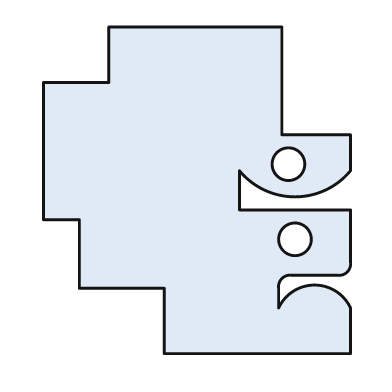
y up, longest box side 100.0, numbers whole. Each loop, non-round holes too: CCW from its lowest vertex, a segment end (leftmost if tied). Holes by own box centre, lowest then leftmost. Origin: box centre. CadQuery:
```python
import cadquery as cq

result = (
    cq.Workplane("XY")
    .moveTo(-10.0, -50.0)
    .lineTo(47.0, -50.0)
    .lineTo(47.0, -36.0)
    .threePointArc((36.0, -29.0), (25.0, -36.0))
    .lineTo(25.0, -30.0)
    .threePointArc((26.0, -27.0), (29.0, -26.0))
    .lineTo(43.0, -26.0)
    .threePointArc((46.0, -25.0), (47.0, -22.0))
    .lineTo(47.0, -6.0)
    .lineTo(13.0, -6.0)
    .lineTo(13.0, 6.0)
    .threePointArc((30.0, -2.0), (47.0, 6.0))
    .lineTo(47.0, 17.0)
    .lineTo(26.0, 17.0)
    .lineTo(26.0, 50.0)
    .lineTo(-27.0, 50.0)
    .lineTo(-27.0, 33.0)
    .lineTo(-47.0, 33.0)
    .lineTo(-47.0, -9.0)
    .lineTo(-36.0, -9.0)
    .lineTo(-36.0, -30.0)
    .lineTo(-10.0, -30.0)
    .close()
    .moveTo(30.0, -15.0)
    .circle(5.0)
    .moveTo(28.0, 8.0)
    .circle(5.0)
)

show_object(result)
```